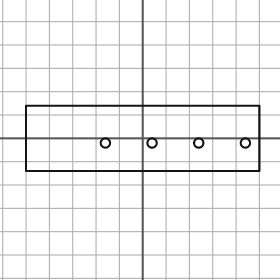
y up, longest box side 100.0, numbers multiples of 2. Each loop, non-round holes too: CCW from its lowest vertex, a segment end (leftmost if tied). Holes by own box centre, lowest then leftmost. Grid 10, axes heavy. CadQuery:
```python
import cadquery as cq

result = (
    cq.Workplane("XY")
    .moveTo(-50.0, -14.0)
    .lineTo(50.0, -14.0)
    .lineTo(50.0, 14.0)
    .lineTo(-50.0, 14.0)
    .close()
    .moveTo(-16.0, -2.0)
    .circle(2.0)
    .moveTo(4.0, -2.0)
    .circle(2.0)
    .moveTo(24.0, -2.0)
    .circle(2.0)
    .moveTo(44.0, -2.0)
    .circle(2.0)
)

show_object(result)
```